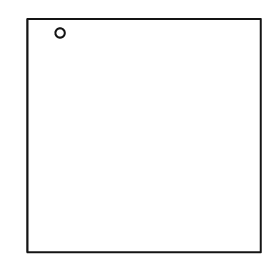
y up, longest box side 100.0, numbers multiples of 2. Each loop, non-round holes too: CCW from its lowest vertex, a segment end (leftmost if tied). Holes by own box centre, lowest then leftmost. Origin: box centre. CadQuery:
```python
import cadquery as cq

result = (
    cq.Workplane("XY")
    .moveTo(-50.0, -50.0)
    .lineTo(50.0, -50.0)
    .lineTo(50.0, 50.0)
    .lineTo(-50.0, 50.0)
    .close()
    .moveTo(-36.0, 44.0)
    .circle(2.0)
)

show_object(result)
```